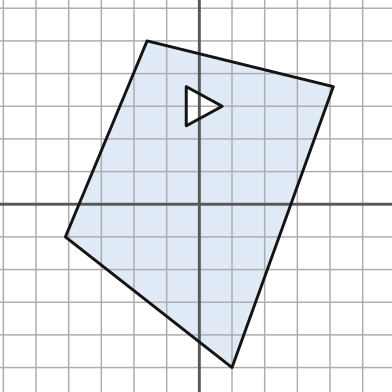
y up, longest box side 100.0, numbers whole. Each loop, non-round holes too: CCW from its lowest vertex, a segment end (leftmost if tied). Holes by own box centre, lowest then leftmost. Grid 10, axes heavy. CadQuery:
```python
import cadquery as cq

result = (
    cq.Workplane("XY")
    .moveTo(10.0, -50.0)
    .lineTo(41.0, 36.0)
    .lineTo(-16.0, 50.0)
    .lineTo(-41.0, -10.0)
    .close()
    .moveTo(-4.0, 24.0)
    .lineTo(7.0, 30.0)
    .lineTo(-4.0, 36.0)
    .close()
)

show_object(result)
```